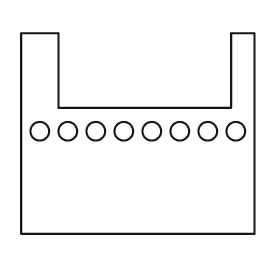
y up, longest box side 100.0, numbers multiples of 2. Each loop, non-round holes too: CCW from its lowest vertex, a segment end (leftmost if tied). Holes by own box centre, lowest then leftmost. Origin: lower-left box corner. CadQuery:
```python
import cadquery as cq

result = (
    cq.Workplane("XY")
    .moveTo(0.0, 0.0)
    .lineTo(100.0, 0.0)
    .lineTo(100.0, 86.0)
    .lineTo(90.0, 86.0)
    .lineTo(90.0, 54.0)
    .lineTo(16.0, 54.0)
    .lineTo(16.0, 86.0)
    .lineTo(0.0, 86.0)
    .close()
    .moveTo(8.0, 44.0)
    .circle(4.0)
    .moveTo(20.0, 44.0)
    .circle(4.0)
    .moveTo(32.0, 44.0)
    .circle(4.0)
    .moveTo(44.0, 44.0)
    .circle(4.0)
    .moveTo(56.0, 44.0)
    .circle(4.0)
    .moveTo(68.0, 44.0)
    .circle(4.0)
    .moveTo(80.0, 44.0)
    .circle(4.0)
    .moveTo(92.0, 44.0)
    .circle(4.0)
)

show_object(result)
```